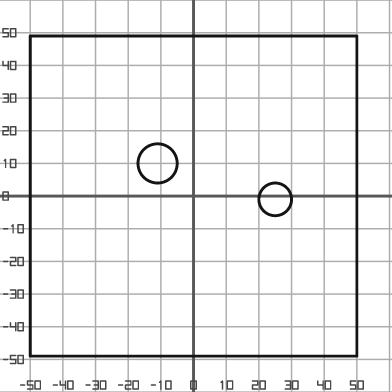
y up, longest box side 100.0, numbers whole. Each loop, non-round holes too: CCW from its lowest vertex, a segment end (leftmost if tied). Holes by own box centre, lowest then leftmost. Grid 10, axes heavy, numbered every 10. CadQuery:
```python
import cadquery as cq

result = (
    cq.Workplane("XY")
    .moveTo(-50.0, -49.0)
    .lineTo(50.0, -49.0)
    .lineTo(50.0, 49.0)
    .lineTo(-50.0, 49.0)
    .close()
    .moveTo(25.0, -1.0)
    .circle(5.0)
    .moveTo(-11.0, 10.0)
    .circle(6.0)
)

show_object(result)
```